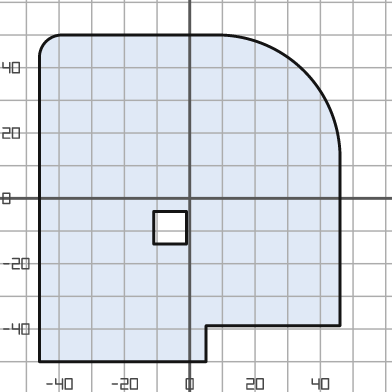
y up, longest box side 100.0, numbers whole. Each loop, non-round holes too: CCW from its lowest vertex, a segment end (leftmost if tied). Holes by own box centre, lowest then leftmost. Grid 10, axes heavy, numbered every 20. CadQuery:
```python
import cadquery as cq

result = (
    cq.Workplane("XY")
    .moveTo(-46.0, -50.0)
    .lineTo(5.0, -50.0)
    .lineTo(5.0, -39.0)
    .lineTo(46.0, -39.0)
    .lineTo(46.0, 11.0)
    .threePointArc((35.0, 39.0), (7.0, 50.0))
    .lineTo(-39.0, 50.0)
    .threePointArc((-44.0, 48.0), (-46.0, 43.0))
    .close()
    .moveTo(-11.0, -14.0)
    .lineTo(-1.0, -14.0)
    .lineTo(-1.0, -4.0)
    .lineTo(-11.0, -4.0)
    .close()
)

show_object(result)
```